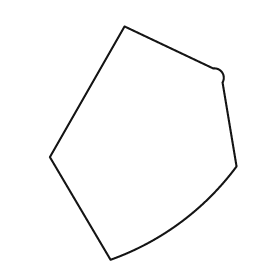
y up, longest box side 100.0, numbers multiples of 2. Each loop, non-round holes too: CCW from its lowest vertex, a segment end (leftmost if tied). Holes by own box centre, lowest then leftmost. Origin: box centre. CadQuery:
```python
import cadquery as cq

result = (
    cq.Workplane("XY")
    .moveTo(-14.0, -50.0)
    .threePointArc((16.0, -34.0), (40.0, -10.0))
    .lineTo(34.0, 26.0)
    .threePointArc((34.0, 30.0), (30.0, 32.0))
    .lineTo(-8.0, 50.0)
    .lineTo(-40.0, -6.0)
    .close()
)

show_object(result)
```